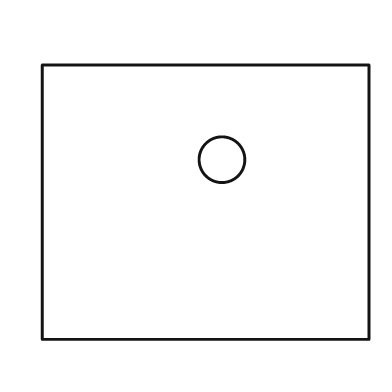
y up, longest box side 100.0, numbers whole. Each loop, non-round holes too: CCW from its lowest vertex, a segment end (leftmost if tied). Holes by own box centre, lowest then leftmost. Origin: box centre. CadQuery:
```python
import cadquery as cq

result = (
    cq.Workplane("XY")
    .moveTo(-50.0, -42.0)
    .lineTo(50.0, -42.0)
    .lineTo(50.0, 42.0)
    .lineTo(-50.0, 42.0)
    .close()
    .moveTo(5.0, 13.0)
    .circle(7.0)
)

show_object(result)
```